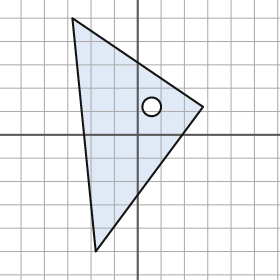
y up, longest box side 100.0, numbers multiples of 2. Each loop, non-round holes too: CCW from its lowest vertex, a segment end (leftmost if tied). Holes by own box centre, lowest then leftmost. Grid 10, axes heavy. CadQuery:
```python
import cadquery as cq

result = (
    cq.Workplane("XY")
    .moveTo(-18.0, -50.0)
    .lineTo(28.0, 12.0)
    .lineTo(-28.0, 50.0)
    .close()
    .moveTo(6.0, 12.0)
    .circle(4.0)
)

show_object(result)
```